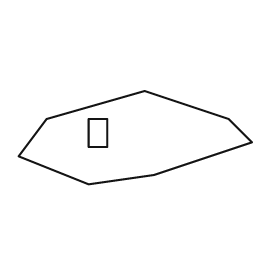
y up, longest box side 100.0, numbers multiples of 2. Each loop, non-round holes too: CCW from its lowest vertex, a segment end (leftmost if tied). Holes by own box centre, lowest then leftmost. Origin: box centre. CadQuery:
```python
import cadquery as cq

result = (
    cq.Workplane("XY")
    .moveTo(-20.0, -20.0)
    .lineTo(8.0, -16.0)
    .lineTo(50.0, -2.0)
    .lineTo(40.0, 8.0)
    .lineTo(4.0, 20.0)
    .lineTo(-38.0, 8.0)
    .lineTo(-50.0, -8.0)
    .close()
    .moveTo(-20.0, -4.0)
    .lineTo(-12.0, -4.0)
    .lineTo(-12.0, 8.0)
    .lineTo(-20.0, 8.0)
    .close()
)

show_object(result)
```